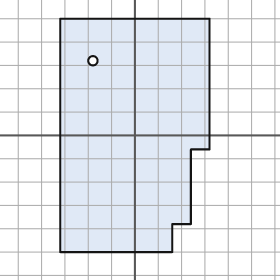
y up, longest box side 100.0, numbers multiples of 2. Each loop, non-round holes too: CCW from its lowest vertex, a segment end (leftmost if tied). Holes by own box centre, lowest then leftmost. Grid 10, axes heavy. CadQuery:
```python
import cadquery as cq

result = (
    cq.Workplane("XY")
    .moveTo(-32.0, -50.0)
    .lineTo(16.0, -50.0)
    .lineTo(16.0, -38.0)
    .lineTo(24.0, -38.0)
    .lineTo(24.0, -6.0)
    .lineTo(32.0, -6.0)
    .lineTo(32.0, 50.0)
    .lineTo(-32.0, 50.0)
    .close()
    .moveTo(-18.0, 32.0)
    .circle(2.0)
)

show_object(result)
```